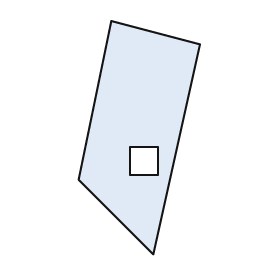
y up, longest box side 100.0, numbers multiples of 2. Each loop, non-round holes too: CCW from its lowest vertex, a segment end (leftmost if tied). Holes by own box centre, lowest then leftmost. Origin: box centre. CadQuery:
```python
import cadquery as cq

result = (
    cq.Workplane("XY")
    .moveTo(6.0, -50.0)
    .lineTo(26.0, 40.0)
    .lineTo(-12.0, 50.0)
    .lineTo(-26.0, -18.0)
    .close()
    .moveTo(-4.0, -16.0)
    .lineTo(8.0, -16.0)
    .lineTo(8.0, -4.0)
    .lineTo(-4.0, -4.0)
    .close()
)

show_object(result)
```